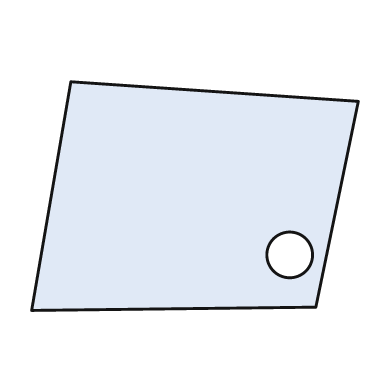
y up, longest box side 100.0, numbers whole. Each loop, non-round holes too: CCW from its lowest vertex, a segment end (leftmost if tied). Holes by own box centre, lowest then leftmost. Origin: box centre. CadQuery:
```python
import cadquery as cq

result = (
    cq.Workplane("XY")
    .moveTo(-50.0, -35.0)
    .lineTo(37.0, -34.0)
    .lineTo(50.0, 29.0)
    .lineTo(-38.0, 35.0)
    .close()
    .moveTo(29.0, -18.0)
    .circle(7.0)
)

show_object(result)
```